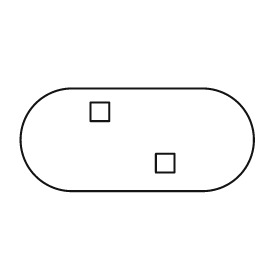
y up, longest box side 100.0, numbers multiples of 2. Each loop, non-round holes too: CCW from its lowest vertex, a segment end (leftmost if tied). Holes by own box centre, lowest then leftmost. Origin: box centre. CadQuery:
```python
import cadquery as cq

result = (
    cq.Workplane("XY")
    .moveTo(-28.0, -22.0)
    .lineTo(28.0, -22.0)
    .threePointArc((50.0, 0.0), (28.0, 22.0))
    .lineTo(-28.0, 22.0)
    .threePointArc((-50.0, 0.0), (-28.0, -22.0))
    .close()
    .moveTo(8.0, -14.0)
    .lineTo(16.0, -14.0)
    .lineTo(16.0, -6.0)
    .lineTo(8.0, -6.0)
    .close()
    .moveTo(-20.0, 8.0)
    .lineTo(-12.0, 8.0)
    .lineTo(-12.0, 16.0)
    .lineTo(-20.0, 16.0)
    .close()
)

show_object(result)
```